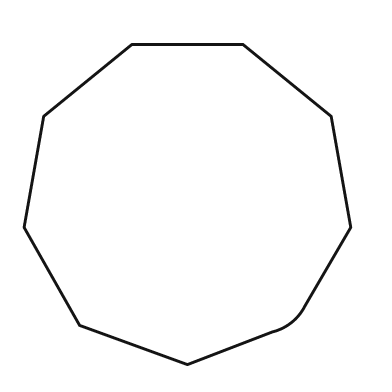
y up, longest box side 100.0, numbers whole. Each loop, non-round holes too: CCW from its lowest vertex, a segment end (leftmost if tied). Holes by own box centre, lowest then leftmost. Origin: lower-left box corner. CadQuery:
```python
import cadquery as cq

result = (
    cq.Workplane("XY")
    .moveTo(50.0, 0.0)
    .lineTo(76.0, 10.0)
    .threePointArc((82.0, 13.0), (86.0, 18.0))
    .lineTo(100.0, 42.0)
    .lineTo(94.0, 76.0)
    .lineTo(67.0, 98.0)
    .lineTo(33.0, 98.0)
    .lineTo(6.0, 76.0)
    .lineTo(0.0, 42.0)
    .lineTo(17.0, 12.0)
    .close()
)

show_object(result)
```